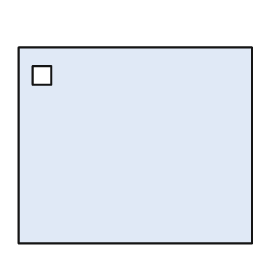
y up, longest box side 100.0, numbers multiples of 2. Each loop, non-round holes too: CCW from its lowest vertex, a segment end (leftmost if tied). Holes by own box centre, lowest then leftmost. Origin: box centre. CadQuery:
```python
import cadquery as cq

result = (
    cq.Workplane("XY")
    .moveTo(-50.0, -42.0)
    .lineTo(50.0, -42.0)
    .lineTo(50.0, 42.0)
    .lineTo(-50.0, 42.0)
    .close()
    .moveTo(-44.0, 26.0)
    .lineTo(-36.0, 26.0)
    .lineTo(-36.0, 34.0)
    .lineTo(-44.0, 34.0)
    .close()
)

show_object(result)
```